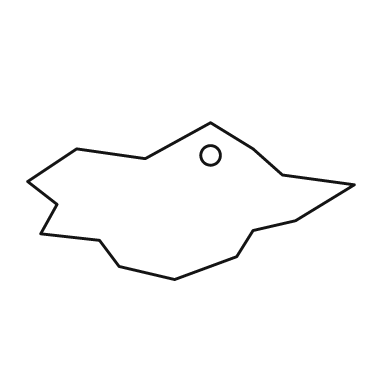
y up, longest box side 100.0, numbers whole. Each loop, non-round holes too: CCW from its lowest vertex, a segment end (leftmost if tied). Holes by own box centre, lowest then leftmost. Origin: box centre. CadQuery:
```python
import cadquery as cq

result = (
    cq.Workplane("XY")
    .moveTo(-5.0, -24.0)
    .lineTo(14.0, -17.0)
    .lineTo(19.0, -9.0)
    .lineTo(32.0, -6.0)
    .lineTo(50.0, 5.0)
    .lineTo(28.0, 8.0)
    .lineTo(19.0, 16.0)
    .lineTo(6.0, 24.0)
    .lineTo(-14.0, 13.0)
    .lineTo(-35.0, 16.0)
    .lineTo(-50.0, 6.0)
    .lineTo(-41.0, -1.0)
    .lineTo(-46.0, -10.0)
    .lineTo(-28.0, -12.0)
    .lineTo(-22.0, -20.0)
    .close()
    .moveTo(6.0, 14.0)
    .circle(3.0)
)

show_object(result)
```